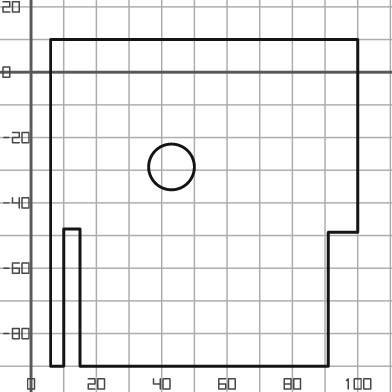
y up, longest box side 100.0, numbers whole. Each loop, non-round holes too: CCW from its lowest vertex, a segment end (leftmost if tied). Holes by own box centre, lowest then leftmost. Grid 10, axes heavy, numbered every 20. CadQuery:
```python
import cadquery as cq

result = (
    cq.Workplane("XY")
    .moveTo(6.0, -90.0)
    .lineTo(10.0, -90.0)
    .lineTo(10.0, -48.0)
    .lineTo(15.0, -48.0)
    .lineTo(15.0, -90.0)
    .lineTo(91.0, -90.0)
    .lineTo(91.0, -49.0)
    .lineTo(100.0, -49.0)
    .lineTo(100.0, 10.0)
    .lineTo(6.0, 10.0)
    .close()
    .moveTo(43.0, -29.0)
    .circle(7.0)
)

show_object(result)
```